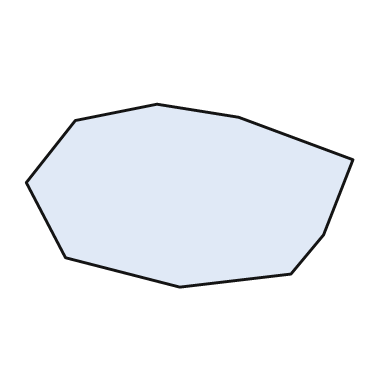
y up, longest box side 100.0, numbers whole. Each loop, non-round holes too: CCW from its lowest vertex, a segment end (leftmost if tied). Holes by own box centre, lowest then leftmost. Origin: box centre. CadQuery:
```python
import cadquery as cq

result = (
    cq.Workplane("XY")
    .moveTo(-3.0, -28.0)
    .lineTo(31.0, -24.0)
    .lineTo(41.0, -12.0)
    .lineTo(50.0, 11.0)
    .lineTo(15.0, 24.0)
    .lineTo(-10.0, 28.0)
    .lineTo(-35.0, 23.0)
    .lineTo(-50.0, 4.0)
    .lineTo(-38.0, -19.0)
    .close()
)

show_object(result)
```